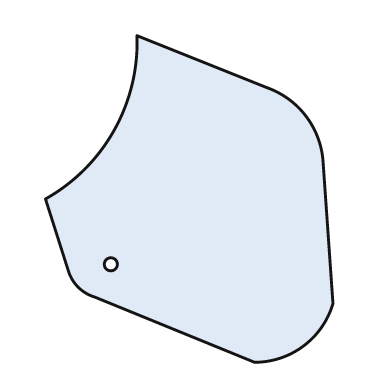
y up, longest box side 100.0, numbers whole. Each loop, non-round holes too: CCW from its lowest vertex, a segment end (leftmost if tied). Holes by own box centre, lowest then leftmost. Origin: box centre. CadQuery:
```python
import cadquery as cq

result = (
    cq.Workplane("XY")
    .moveTo(20.0, -50.0)
    .threePointArc((35.0, -45.0), (44.0, -32.0))
    .lineTo(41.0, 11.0)
    .threePointArc((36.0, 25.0), (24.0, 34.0))
    .lineTo(-16.0, 50.0)
    .threePointArc((-23.0, 21.0), (-44.0, 0.0))
    .lineTo(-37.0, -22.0)
    .threePointArc((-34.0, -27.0), (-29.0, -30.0))
    .close()
    .moveTo(-24.0, -20.0)
    .circle(2.0)
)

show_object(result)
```